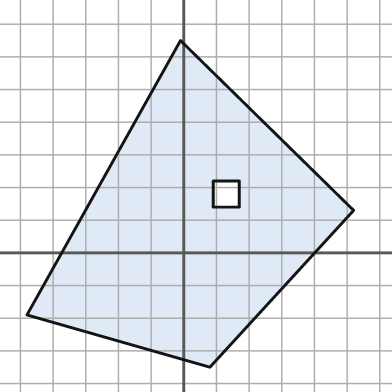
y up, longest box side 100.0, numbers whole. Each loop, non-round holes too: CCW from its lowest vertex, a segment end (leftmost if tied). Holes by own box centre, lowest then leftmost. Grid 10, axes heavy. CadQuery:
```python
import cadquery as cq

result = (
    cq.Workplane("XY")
    .moveTo(8.0, -35.0)
    .lineTo(52.0, 13.0)
    .lineTo(-1.0, 65.0)
    .lineTo(-48.0, -19.0)
    .close()
    .moveTo(9.0, 14.0)
    .lineTo(17.0, 14.0)
    .lineTo(17.0, 22.0)
    .lineTo(9.0, 22.0)
    .close()
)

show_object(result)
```